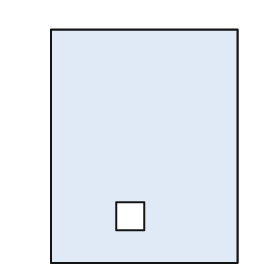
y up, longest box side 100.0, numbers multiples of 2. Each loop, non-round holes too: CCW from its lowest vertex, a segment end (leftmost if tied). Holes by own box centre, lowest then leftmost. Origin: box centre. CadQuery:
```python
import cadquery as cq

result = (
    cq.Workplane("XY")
    .moveTo(-40.0, -50.0)
    .lineTo(40.0, -50.0)
    .lineTo(40.0, 50.0)
    .lineTo(-40.0, 50.0)
    .close()
    .moveTo(-12.0, -36.0)
    .lineTo(0.0, -36.0)
    .lineTo(0.0, -24.0)
    .lineTo(-12.0, -24.0)
    .close()
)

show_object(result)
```